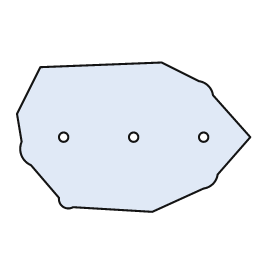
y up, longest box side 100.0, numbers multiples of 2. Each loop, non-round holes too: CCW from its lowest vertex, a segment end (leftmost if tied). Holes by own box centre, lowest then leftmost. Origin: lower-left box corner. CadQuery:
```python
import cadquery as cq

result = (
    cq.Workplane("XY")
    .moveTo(58.0, 0.0)
    .lineTo(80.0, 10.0)
    .threePointArc((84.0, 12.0), (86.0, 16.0))
    .lineTo(100.0, 32.0)
    .lineTo(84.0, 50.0)
    .threePointArc((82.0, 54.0), (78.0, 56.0))
    .lineTo(62.0, 64.0)
    .lineTo(10.0, 62.0)
    .lineTo(0.0, 42.0)
    .lineTo(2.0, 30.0)
    .threePointArc((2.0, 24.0), (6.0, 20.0))
    .lineTo(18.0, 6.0)
    .threePointArc((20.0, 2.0), (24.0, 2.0))
    .close()
    .moveTo(20.0, 32.0)
    .circle(2.0)
    .moveTo(50.0, 32.0)
    .circle(2.0)
    .moveTo(80.0, 32.0)
    .circle(2.0)
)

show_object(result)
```